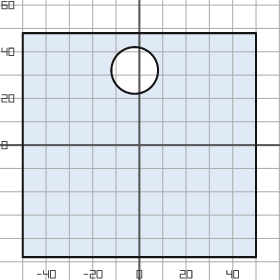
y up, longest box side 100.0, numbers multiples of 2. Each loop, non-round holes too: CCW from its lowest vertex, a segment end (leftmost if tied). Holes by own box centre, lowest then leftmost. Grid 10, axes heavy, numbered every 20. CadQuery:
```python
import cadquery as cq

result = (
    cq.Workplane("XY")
    .moveTo(-50.0, -48.0)
    .lineTo(50.0, -48.0)
    .lineTo(50.0, 48.0)
    .lineTo(-50.0, 48.0)
    .close()
    .moveTo(-2.0, 32.0)
    .circle(10.0)
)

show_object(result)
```